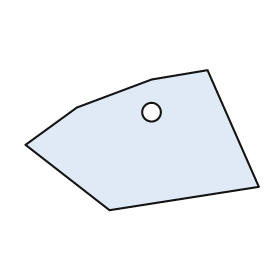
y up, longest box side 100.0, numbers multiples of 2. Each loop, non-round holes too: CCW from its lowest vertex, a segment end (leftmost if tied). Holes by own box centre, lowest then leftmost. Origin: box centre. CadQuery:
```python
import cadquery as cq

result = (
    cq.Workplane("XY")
    .moveTo(-14.0, -30.0)
    .lineTo(50.0, -20.0)
    .lineTo(28.0, 30.0)
    .lineTo(4.0, 26.0)
    .lineTo(-28.0, 14.0)
    .lineTo(-50.0, -2.0)
    .close()
    .moveTo(4.0, 12.0)
    .circle(4.0)
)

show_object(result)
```